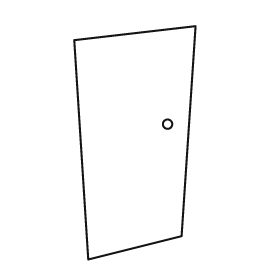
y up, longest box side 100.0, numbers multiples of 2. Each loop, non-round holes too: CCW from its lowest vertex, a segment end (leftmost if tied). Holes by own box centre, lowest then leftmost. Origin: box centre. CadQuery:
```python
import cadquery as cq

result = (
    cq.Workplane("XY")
    .moveTo(-20.0, -50.0)
    .lineTo(20.0, -40.0)
    .lineTo(26.0, 50.0)
    .lineTo(-26.0, 44.0)
    .close()
    .moveTo(14.0, 8.0)
    .circle(2.0)
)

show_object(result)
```